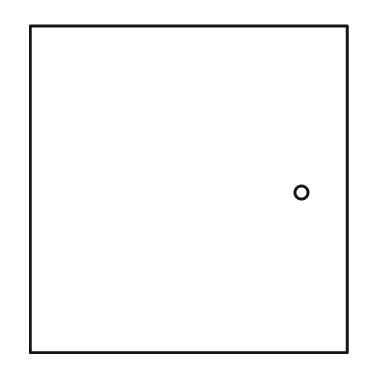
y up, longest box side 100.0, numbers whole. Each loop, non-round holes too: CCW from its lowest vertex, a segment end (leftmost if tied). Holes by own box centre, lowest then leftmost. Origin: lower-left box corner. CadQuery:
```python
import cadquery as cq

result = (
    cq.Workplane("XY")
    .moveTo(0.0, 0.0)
    .lineTo(97.0, 0.0)
    .lineTo(97.0, 100.0)
    .lineTo(0.0, 100.0)
    .close()
    .moveTo(83.0, 49.0)
    .circle(2.0)
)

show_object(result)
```